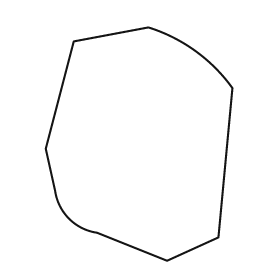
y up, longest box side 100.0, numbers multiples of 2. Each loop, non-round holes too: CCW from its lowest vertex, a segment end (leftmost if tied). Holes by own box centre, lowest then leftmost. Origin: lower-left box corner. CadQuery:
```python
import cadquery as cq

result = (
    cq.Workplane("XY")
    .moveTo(52.0, 0.0)
    .lineTo(74.0, 10.0)
    .lineTo(80.0, 74.0)
    .threePointArc((64.0, 90.0), (44.0, 100.0))
    .lineTo(12.0, 94.0)
    .lineTo(0.0, 48.0)
    .lineTo(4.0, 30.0)
    .threePointArc((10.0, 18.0), (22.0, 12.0))
    .close()
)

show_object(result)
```